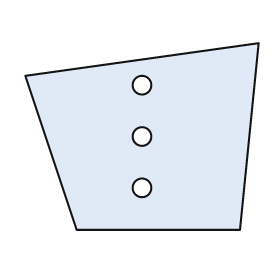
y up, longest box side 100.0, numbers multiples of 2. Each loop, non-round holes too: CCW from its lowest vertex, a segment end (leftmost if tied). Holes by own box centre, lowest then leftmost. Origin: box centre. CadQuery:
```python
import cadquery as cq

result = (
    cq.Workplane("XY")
    .moveTo(-28.0, -40.0)
    .lineTo(42.0, -40.0)
    .lineTo(50.0, 40.0)
    .lineTo(-50.0, 26.0)
    .close()
    .moveTo(0.0, -22.0)
    .circle(4.0)
    .moveTo(0.0, 0.0)
    .circle(4.0)
    .moveTo(0.0, 22.0)
    .circle(4.0)
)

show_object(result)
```